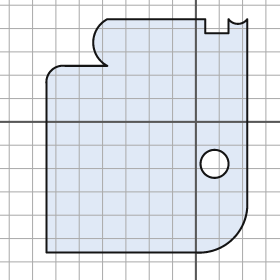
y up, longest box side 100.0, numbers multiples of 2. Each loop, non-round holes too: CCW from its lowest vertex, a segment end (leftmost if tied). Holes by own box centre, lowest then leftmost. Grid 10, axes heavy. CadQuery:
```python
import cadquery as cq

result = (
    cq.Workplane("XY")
    .moveTo(-64.0, -56.0)
    .lineTo(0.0, -56.0)
    .threePointArc((16.0, -50.0), (22.0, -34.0))
    .lineTo(22.0, 44.0)
    .threePointArc((18.0, 42.0), (14.0, 44.0))
    .lineTo(14.0, 38.0)
    .lineTo(4.0, 38.0)
    .lineTo(4.0, 44.0)
    .lineTo(-38.0, 44.0)
    .threePointArc((-44.0, 34.0), (-38.0, 24.0))
    .lineTo(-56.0, 24.0)
    .threePointArc((-62.0, 22.0), (-64.0, 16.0))
    .close()
    .moveTo(8.0, -18.0)
    .circle(6.0)
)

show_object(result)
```